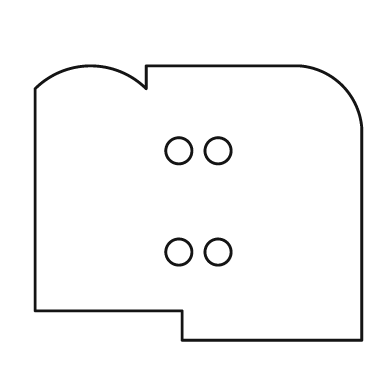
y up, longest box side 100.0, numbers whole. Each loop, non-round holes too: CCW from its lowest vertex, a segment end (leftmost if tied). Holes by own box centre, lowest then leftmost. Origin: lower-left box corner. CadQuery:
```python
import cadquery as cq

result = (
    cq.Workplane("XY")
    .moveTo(45.0, 0.0)
    .lineTo(100.0, 0.0)
    .lineTo(100.0, 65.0)
    .threePointArc((94.0, 78.0), (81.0, 84.0))
    .lineTo(34.0, 84.0)
    .lineTo(34.0, 77.0)
    .threePointArc((17.0, 84.0), (0.0, 77.0))
    .lineTo(0.0, 9.0)
    .lineTo(45.0, 9.0)
    .close()
    .moveTo(44.0, 27.0)
    .circle(4.0)
    .moveTo(56.0, 27.0)
    .circle(4.0)
    .moveTo(44.0, 58.0)
    .circle(4.0)
    .moveTo(56.0, 58.0)
    .circle(4.0)
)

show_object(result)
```